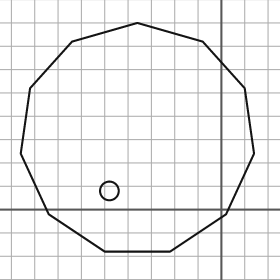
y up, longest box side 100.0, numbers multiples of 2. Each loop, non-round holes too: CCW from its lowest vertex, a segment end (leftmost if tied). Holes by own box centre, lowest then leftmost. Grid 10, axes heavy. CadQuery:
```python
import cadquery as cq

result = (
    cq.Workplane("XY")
    .moveTo(-50.0, -18.0)
    .lineTo(-22.0, -18.0)
    .lineTo(2.0, -2.0)
    .lineTo(14.0, 24.0)
    .lineTo(10.0, 52.0)
    .lineTo(-8.0, 72.0)
    .lineTo(-36.0, 80.0)
    .lineTo(-64.0, 72.0)
    .lineTo(-82.0, 52.0)
    .lineTo(-86.0, 24.0)
    .lineTo(-74.0, -2.0)
    .close()
    .moveTo(-48.0, 8.0)
    .circle(4.0)
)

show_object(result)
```